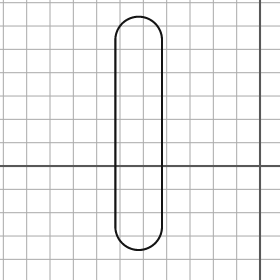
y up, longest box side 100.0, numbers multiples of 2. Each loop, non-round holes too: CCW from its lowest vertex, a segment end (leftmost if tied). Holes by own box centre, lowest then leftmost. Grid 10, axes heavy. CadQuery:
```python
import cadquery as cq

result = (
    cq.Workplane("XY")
    .moveTo(-62.0, -26.0)
    .threePointArc((-52.0, -36.0), (-42.0, -26.0))
    .lineTo(-42.0, 54.0)
    .threePointArc((-52.0, 64.0), (-62.0, 54.0))
    .close()
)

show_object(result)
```